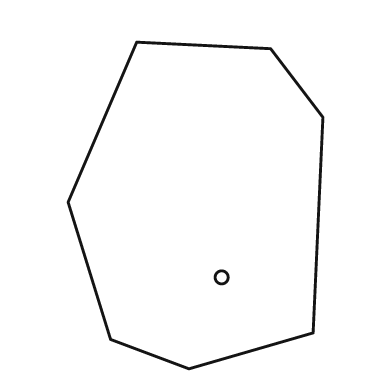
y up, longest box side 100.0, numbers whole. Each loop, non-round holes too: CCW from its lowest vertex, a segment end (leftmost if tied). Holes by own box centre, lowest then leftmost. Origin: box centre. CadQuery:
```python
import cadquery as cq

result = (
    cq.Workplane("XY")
    .moveTo(-2.0, -50.0)
    .lineTo(36.0, -39.0)
    .lineTo(39.0, 27.0)
    .lineTo(23.0, 48.0)
    .lineTo(-18.0, 50.0)
    .lineTo(-39.0, 1.0)
    .lineTo(-26.0, -41.0)
    .close()
    .moveTo(8.0, -22.0)
    .circle(2.0)
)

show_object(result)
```